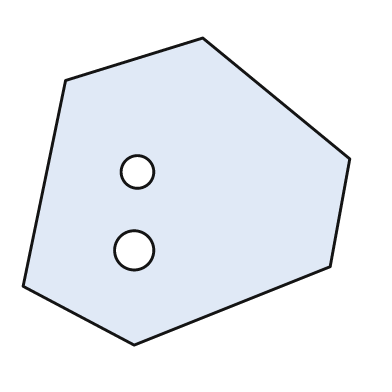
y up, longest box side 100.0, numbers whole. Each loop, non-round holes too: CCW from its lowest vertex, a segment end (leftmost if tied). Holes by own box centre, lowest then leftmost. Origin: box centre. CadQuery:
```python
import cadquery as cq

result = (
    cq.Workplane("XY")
    .moveTo(-16.0, -47.0)
    .lineTo(44.0, -23.0)
    .lineTo(50.0, 10.0)
    .lineTo(5.0, 47.0)
    .lineTo(-37.0, 34.0)
    .lineTo(-50.0, -29.0)
    .close()
    .moveTo(-16.0, -18.0)
    .circle(6.0)
    .moveTo(-15.0, 6.0)
    .circle(5.0)
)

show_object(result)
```